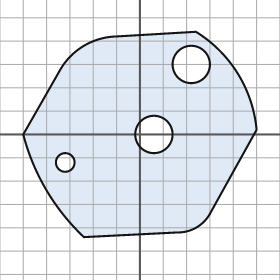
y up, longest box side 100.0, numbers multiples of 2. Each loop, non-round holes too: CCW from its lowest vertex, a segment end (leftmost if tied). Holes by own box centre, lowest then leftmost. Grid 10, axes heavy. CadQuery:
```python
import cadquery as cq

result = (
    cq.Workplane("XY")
    .moveTo(-24.0, -44.0)
    .lineTo(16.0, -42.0)
    .threePointArc((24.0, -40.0), (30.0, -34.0))
    .lineTo(50.0, 2.0)
    .threePointArc((42.0, 26.0), (24.0, 44.0))
    .lineTo(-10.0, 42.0)
    .threePointArc((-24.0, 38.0), (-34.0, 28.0))
    .lineTo(-50.0, 0.0)
    .threePointArc((-40.0, -24.0), (-24.0, -44.0))
    .close()
    .moveTo(-32.0, -12.0)
    .circle(4.0)
    .moveTo(6.0, 0.0)
    .circle(8.0)
    .moveTo(22.0, 30.0)
    .circle(8.0)
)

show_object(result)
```